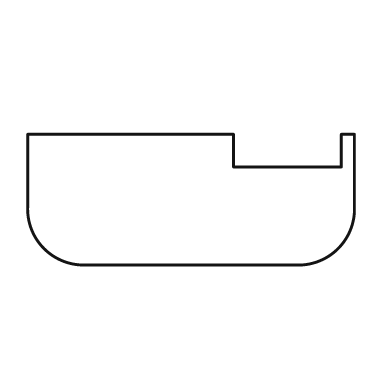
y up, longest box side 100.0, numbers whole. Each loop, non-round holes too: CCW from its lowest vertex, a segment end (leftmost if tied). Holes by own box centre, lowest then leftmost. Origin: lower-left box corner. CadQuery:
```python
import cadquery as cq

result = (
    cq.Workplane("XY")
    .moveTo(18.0, 0.0)
    .lineTo(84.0, 0.0)
    .threePointArc((95.0, 5.0), (100.0, 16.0))
    .lineTo(100.0, 40.0)
    .lineTo(96.0, 40.0)
    .lineTo(96.0, 30.0)
    .lineTo(63.0, 30.0)
    .lineTo(63.0, 40.0)
    .lineTo(0.0, 40.0)
    .lineTo(0.0, 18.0)
    .threePointArc((5.0, 5.0), (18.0, 0.0))
    .close()
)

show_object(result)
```